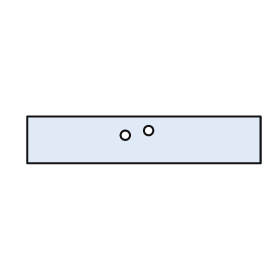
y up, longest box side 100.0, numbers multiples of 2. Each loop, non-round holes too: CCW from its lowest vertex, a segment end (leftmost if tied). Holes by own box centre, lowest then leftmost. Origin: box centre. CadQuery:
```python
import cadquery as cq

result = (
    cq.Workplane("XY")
    .moveTo(-50.0, -10.0)
    .lineTo(50.0, -10.0)
    .lineTo(50.0, 10.0)
    .lineTo(-50.0, 10.0)
    .close()
    .moveTo(-8.0, 2.0)
    .circle(2.0)
    .moveTo(2.0, 4.0)
    .circle(2.0)
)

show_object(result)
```